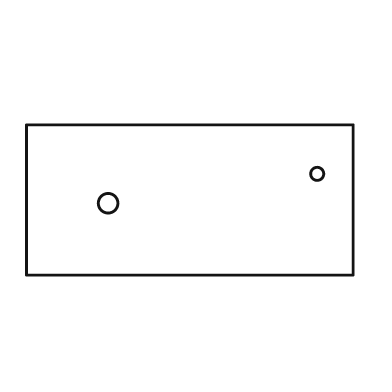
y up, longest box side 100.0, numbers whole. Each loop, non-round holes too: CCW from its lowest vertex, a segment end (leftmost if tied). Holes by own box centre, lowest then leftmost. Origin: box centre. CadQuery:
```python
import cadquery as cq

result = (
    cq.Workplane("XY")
    .moveTo(-50.0, -23.0)
    .lineTo(50.0, -23.0)
    .lineTo(50.0, 23.0)
    .lineTo(-50.0, 23.0)
    .close()
    .moveTo(-25.0, -1.0)
    .circle(3.0)
    .moveTo(39.0, 8.0)
    .circle(2.0)
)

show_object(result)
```